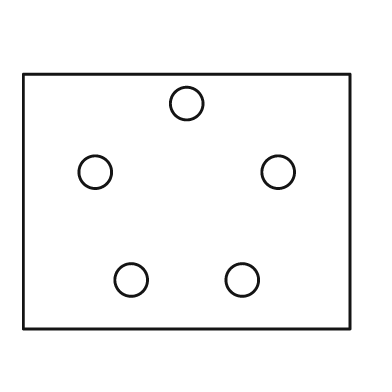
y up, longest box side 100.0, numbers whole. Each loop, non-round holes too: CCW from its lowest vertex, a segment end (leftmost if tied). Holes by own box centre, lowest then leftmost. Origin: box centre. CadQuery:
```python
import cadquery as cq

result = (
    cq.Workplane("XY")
    .moveTo(-50.0, -39.0)
    .lineTo(50.0, -39.0)
    .lineTo(50.0, 39.0)
    .lineTo(-50.0, 39.0)
    .close()
    .moveTo(-17.0, -24.0)
    .circle(5.0)
    .moveTo(17.0, -24.0)
    .circle(5.0)
    .moveTo(-28.0, 9.0)
    .circle(5.0)
    .moveTo(28.0, 9.0)
    .circle(5.0)
    .moveTo(0.0, 30.0)
    .circle(5.0)
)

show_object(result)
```